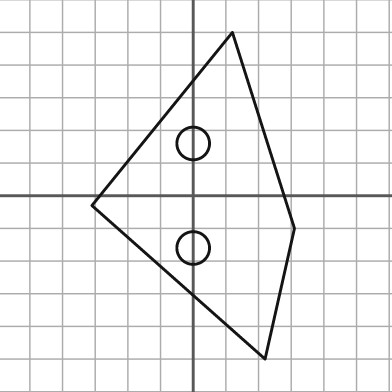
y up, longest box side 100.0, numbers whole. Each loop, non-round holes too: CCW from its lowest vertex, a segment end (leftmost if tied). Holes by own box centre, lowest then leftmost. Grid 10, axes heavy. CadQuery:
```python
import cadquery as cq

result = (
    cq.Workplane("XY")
    .moveTo(22.0, -50.0)
    .lineTo(31.0, -10.0)
    .lineTo(12.0, 50.0)
    .lineTo(-31.0, -3.0)
    .close()
    .moveTo(0.0, -16.0)
    .circle(5.0)
    .moveTo(0.0, 16.0)
    .circle(5.0)
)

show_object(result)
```